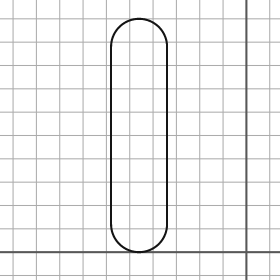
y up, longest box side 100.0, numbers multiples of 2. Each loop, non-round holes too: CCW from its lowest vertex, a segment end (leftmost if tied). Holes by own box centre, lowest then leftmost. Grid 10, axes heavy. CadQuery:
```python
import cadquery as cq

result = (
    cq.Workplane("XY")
    .moveTo(-58.0, 12.0)
    .threePointArc((-46.0, 0.0), (-34.0, 12.0))
    .lineTo(-34.0, 88.0)
    .threePointArc((-46.0, 100.0), (-58.0, 88.0))
    .close()
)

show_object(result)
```